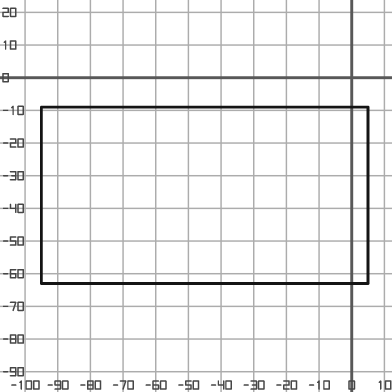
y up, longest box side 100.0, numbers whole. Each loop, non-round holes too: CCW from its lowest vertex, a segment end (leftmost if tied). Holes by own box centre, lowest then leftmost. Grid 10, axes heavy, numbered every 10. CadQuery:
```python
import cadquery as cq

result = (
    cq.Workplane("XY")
    .moveTo(-95.0, -63.0)
    .lineTo(5.0, -63.0)
    .lineTo(5.0, -9.0)
    .lineTo(-95.0, -9.0)
    .close()
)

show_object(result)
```